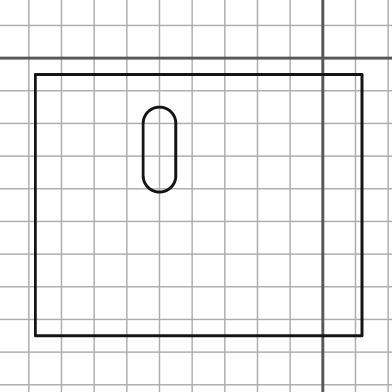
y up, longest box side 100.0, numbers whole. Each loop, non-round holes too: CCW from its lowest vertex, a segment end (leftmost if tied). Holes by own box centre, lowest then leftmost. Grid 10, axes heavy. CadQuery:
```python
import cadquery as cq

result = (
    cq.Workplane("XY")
    .moveTo(-88.0, -85.0)
    .lineTo(12.0, -85.0)
    .lineTo(12.0, -5.0)
    .lineTo(-88.0, -5.0)
    .close()
    .moveTo(-55.0, -36.0)
    .threePointArc((-50.0, -41.0), (-45.0, -36.0))
    .lineTo(-45.0, -20.0)
    .threePointArc((-50.0, -15.0), (-55.0, -20.0))
    .close()
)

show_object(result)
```